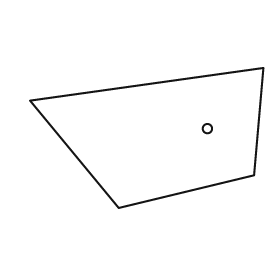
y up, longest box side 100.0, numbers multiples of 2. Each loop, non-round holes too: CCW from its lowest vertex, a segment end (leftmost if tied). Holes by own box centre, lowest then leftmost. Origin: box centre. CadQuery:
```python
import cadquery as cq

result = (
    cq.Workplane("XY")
    .moveTo(-12.0, -30.0)
    .lineTo(46.0, -16.0)
    .lineTo(50.0, 30.0)
    .lineTo(-50.0, 16.0)
    .close()
    .moveTo(26.0, 4.0)
    .circle(2.0)
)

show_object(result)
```